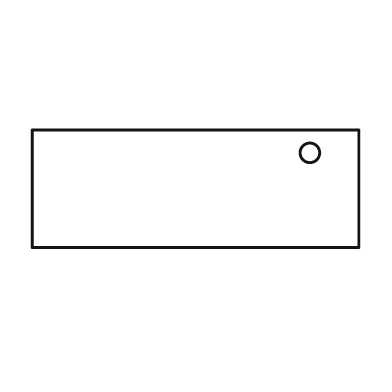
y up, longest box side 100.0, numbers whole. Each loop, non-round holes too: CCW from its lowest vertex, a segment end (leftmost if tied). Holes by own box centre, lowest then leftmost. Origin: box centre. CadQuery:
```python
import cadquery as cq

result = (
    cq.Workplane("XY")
    .moveTo(-50.0, -18.0)
    .lineTo(50.0, -18.0)
    .lineTo(50.0, 18.0)
    .lineTo(-50.0, 18.0)
    .close()
    .moveTo(35.0, 11.0)
    .circle(3.0)
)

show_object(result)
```